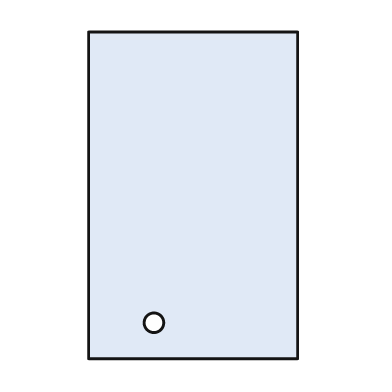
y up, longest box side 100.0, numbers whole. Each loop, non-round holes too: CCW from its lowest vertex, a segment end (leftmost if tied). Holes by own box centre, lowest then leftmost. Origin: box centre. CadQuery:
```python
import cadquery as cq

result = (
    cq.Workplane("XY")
    .moveTo(-32.0, -50.0)
    .lineTo(32.0, -50.0)
    .lineTo(32.0, 50.0)
    .lineTo(-32.0, 50.0)
    .close()
    .moveTo(-12.0, -39.0)
    .circle(3.0)
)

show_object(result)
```